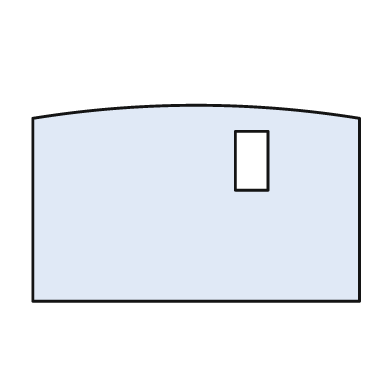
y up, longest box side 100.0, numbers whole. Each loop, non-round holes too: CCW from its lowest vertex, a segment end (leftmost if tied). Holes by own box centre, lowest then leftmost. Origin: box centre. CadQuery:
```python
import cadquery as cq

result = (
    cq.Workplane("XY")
    .moveTo(-50.0, -30.0)
    .lineTo(50.0, -30.0)
    .lineTo(50.0, 26.0)
    .threePointArc((0.0, 30.0), (-50.0, 26.0))
    .close()
    .moveTo(12.0, 4.0)
    .lineTo(22.0, 4.0)
    .lineTo(22.0, 22.0)
    .lineTo(12.0, 22.0)
    .close()
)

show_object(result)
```